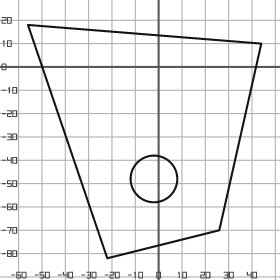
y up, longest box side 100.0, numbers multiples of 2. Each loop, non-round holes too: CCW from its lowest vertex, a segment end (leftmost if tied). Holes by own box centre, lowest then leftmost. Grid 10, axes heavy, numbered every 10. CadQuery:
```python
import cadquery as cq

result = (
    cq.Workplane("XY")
    .moveTo(-22.0, -82.0)
    .lineTo(26.0, -70.0)
    .lineTo(44.0, 10.0)
    .lineTo(-56.0, 18.0)
    .close()
    .moveTo(-2.0, -48.0)
    .circle(10.0)
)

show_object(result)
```